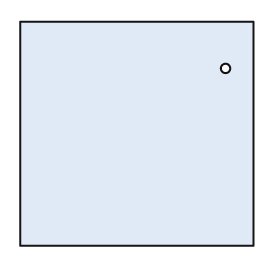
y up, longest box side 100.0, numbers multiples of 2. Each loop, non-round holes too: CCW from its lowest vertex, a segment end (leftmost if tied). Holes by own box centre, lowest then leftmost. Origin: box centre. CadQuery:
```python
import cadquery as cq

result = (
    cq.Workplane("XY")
    .moveTo(-50.0, -48.0)
    .lineTo(50.0, -48.0)
    .lineTo(50.0, 48.0)
    .lineTo(-50.0, 48.0)
    .close()
    .moveTo(38.0, 28.0)
    .circle(2.0)
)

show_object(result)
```